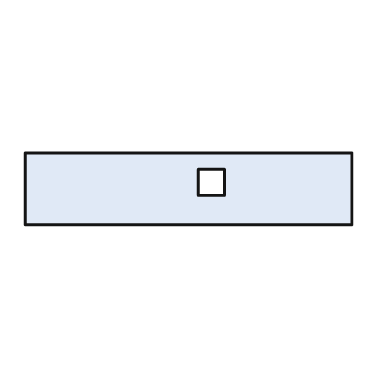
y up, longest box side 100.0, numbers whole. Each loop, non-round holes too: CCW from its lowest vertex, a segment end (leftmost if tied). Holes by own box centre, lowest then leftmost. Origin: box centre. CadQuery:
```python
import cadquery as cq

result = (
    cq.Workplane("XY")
    .moveTo(-50.0, -11.0)
    .lineTo(50.0, -11.0)
    .lineTo(50.0, 11.0)
    .lineTo(-50.0, 11.0)
    .close()
    .moveTo(3.0, -2.0)
    .lineTo(11.0, -2.0)
    .lineTo(11.0, 6.0)
    .lineTo(3.0, 6.0)
    .close()
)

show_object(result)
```